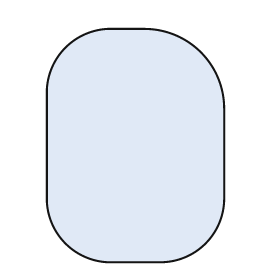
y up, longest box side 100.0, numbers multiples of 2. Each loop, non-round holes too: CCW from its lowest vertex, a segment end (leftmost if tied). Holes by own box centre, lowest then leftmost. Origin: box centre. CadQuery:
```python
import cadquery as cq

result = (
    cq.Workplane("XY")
    .moveTo(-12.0, -50.0)
    .lineTo(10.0, -50.0)
    .threePointArc((30.0, -42.0), (38.0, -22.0))
    .lineTo(38.0, 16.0)
    .threePointArc((28.0, 40.0), (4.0, 50.0))
    .lineTo(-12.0, 50.0)
    .threePointArc((-30.0, 42.0), (-38.0, 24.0))
    .lineTo(-38.0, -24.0)
    .threePointArc((-30.0, -42.0), (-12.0, -50.0))
    .close()
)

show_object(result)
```